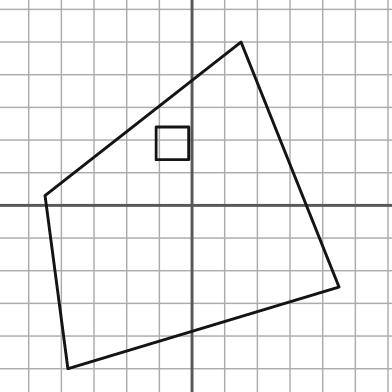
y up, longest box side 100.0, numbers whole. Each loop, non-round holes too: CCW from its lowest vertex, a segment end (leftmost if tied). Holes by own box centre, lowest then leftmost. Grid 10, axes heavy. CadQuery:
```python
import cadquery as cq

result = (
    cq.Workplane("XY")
    .moveTo(-38.0, -50.0)
    .lineTo(45.0, -25.0)
    .lineTo(15.0, 50.0)
    .lineTo(-45.0, 3.0)
    .close()
    .moveTo(-11.0, 14.0)
    .lineTo(-1.0, 14.0)
    .lineTo(-1.0, 24.0)
    .lineTo(-11.0, 24.0)
    .close()
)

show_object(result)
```